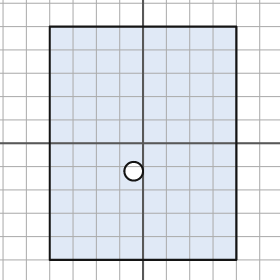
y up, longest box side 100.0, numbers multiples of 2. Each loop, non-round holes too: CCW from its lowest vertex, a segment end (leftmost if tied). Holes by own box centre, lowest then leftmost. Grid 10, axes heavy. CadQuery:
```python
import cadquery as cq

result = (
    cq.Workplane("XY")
    .moveTo(-40.0, -50.0)
    .lineTo(40.0, -50.0)
    .lineTo(40.0, 50.0)
    .lineTo(-40.0, 50.0)
    .close()
    .moveTo(-4.0, -12.0)
    .circle(4.0)
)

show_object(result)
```